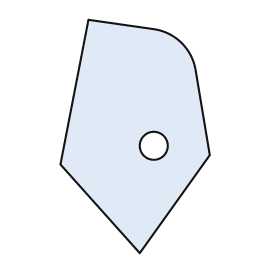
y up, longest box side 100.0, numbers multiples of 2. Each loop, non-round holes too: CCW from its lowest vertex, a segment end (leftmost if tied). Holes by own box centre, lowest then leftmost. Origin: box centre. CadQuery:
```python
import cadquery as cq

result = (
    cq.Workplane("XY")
    .moveTo(2.0, -50.0)
    .lineTo(32.0, -8.0)
    .lineTo(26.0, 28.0)
    .threePointArc((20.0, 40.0), (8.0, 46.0))
    .lineTo(-20.0, 50.0)
    .lineTo(-32.0, -12.0)
    .close()
    .moveTo(8.0, -4.0)
    .circle(6.0)
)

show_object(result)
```